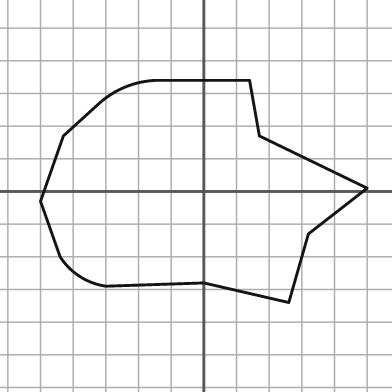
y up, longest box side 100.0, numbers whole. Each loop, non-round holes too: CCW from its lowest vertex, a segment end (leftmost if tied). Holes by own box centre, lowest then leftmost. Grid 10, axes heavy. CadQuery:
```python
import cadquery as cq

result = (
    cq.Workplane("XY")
    .moveTo(26.0, -34.0)
    .lineTo(32.0, -13.0)
    .lineTo(50.0, 1.0)
    .lineTo(17.0, 17.0)
    .lineTo(14.0, 34.0)
    .lineTo(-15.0, 34.0)
    .threePointArc((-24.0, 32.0), (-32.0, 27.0))
    .lineTo(-43.0, 17.0)
    .lineTo(-50.0, -3.0)
    .lineTo(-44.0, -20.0)
    .threePointArc((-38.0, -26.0), (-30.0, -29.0))
    .lineTo(0.0, -28.0)
    .close()
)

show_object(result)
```